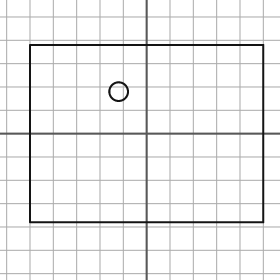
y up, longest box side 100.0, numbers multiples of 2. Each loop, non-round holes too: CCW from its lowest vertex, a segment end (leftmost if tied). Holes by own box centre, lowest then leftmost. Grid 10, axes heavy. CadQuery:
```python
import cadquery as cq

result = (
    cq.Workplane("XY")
    .moveTo(-50.0, -38.0)
    .lineTo(50.0, -38.0)
    .lineTo(50.0, 38.0)
    .lineTo(-50.0, 38.0)
    .close()
    .moveTo(-12.0, 18.0)
    .circle(4.0)
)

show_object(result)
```